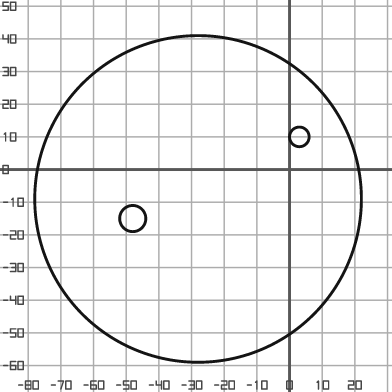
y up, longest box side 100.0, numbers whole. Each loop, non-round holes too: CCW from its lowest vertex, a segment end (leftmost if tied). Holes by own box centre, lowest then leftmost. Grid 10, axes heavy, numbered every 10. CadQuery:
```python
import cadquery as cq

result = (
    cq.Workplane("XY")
    .moveTo(-28.0, -9.0)
    .circle(50.0)
    .moveTo(-48.0, -15.0)
    .circle(4.0)
    .moveTo(3.0, 10.0)
    .circle(3.0)
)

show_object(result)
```